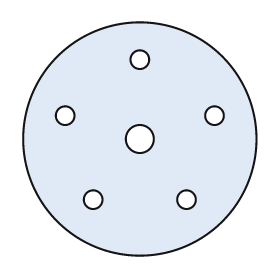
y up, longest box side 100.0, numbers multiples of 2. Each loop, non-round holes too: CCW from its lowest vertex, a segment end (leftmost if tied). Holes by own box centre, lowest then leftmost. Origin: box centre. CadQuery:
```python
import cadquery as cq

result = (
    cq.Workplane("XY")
    .moveTo(0.0, 0.0)
    .circle(50.0)
    .moveTo(-20.0, -26.0)
    .circle(4.0)
    .moveTo(20.0, -26.0)
    .circle(4.0)
    .moveTo(0.0, 0.0)
    .circle(6.0)
    .moveTo(-32.0, 10.0)
    .circle(4.0)
    .moveTo(32.0, 10.0)
    .circle(4.0)
    .moveTo(0.0, 34.0)
    .circle(4.0)
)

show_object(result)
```